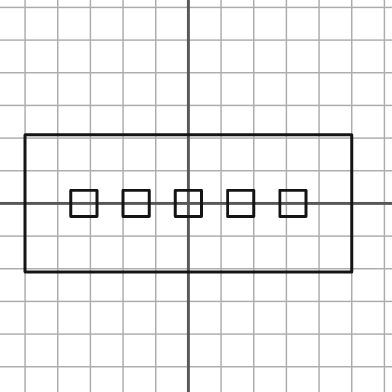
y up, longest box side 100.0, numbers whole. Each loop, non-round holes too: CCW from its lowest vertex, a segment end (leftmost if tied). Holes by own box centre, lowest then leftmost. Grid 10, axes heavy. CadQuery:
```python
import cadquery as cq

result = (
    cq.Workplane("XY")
    .moveTo(-50.0, -21.0)
    .lineTo(50.0, -21.0)
    .lineTo(50.0, 21.0)
    .lineTo(-50.0, 21.0)
    .close()
    .moveTo(-36.0, -4.0)
    .lineTo(-28.0, -4.0)
    .lineTo(-28.0, 4.0)
    .lineTo(-36.0, 4.0)
    .close()
    .moveTo(-20.0, -4.0)
    .lineTo(-12.0, -4.0)
    .lineTo(-12.0, 4.0)
    .lineTo(-20.0, 4.0)
    .close()
    .moveTo(-4.0, -4.0)
    .lineTo(4.0, -4.0)
    .lineTo(4.0, 4.0)
    .lineTo(-4.0, 4.0)
    .close()
    .moveTo(12.0, -4.0)
    .lineTo(20.0, -4.0)
    .lineTo(20.0, 4.0)
    .lineTo(12.0, 4.0)
    .close()
    .moveTo(28.0, -4.0)
    .lineTo(36.0, -4.0)
    .lineTo(36.0, 4.0)
    .lineTo(28.0, 4.0)
    .close()
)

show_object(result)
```